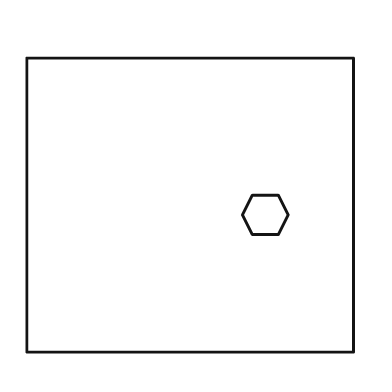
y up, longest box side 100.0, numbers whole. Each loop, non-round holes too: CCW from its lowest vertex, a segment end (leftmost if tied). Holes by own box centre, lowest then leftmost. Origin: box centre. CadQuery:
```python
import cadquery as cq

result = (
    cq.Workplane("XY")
    .moveTo(-50.0, -45.0)
    .lineTo(50.0, -45.0)
    .lineTo(50.0, 45.0)
    .lineTo(-50.0, 45.0)
    .close()
    .moveTo(19.0, -9.0)
    .lineTo(27.0, -9.0)
    .lineTo(30.0, -3.0)
    .lineTo(27.0, 3.0)
    .lineTo(19.0, 3.0)
    .lineTo(16.0, -3.0)
    .close()
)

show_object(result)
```